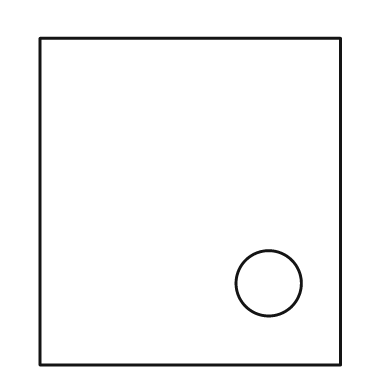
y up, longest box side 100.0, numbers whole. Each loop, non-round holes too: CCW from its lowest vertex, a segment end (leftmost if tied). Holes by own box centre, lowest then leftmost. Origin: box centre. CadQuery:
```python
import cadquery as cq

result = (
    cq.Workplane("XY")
    .moveTo(-46.0, -50.0)
    .lineTo(46.0, -50.0)
    .lineTo(46.0, 50.0)
    .lineTo(-46.0, 50.0)
    .close()
    .moveTo(24.0, -25.0)
    .circle(10.0)
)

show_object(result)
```